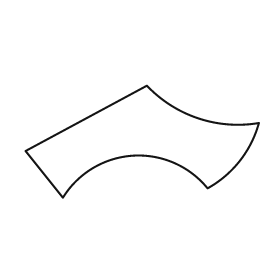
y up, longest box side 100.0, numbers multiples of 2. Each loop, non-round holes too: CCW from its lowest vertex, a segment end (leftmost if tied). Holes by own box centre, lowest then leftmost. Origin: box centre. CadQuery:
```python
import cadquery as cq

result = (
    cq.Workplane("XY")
    .moveTo(-34.0, -24.0)
    .threePointArc((-4.0, -6.0), (28.0, -20.0))
    .threePointArc((42.0, -8.0), (50.0, 8.0))
    .threePointArc((24.0, 10.0), (2.0, 24.0))
    .lineTo(-50.0, -4.0)
    .close()
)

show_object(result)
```